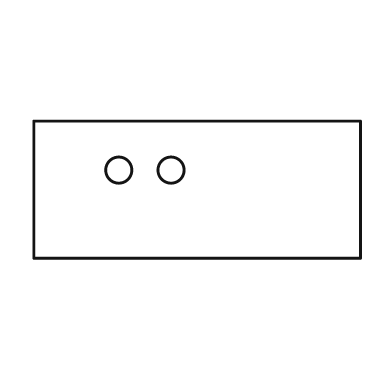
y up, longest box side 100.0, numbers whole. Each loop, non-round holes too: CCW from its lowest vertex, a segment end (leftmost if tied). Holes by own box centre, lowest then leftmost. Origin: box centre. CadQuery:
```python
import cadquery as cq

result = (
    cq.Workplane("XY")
    .moveTo(-50.0, -21.0)
    .lineTo(50.0, -21.0)
    .lineTo(50.0, 21.0)
    .lineTo(-50.0, 21.0)
    .close()
    .moveTo(-24.0, 6.0)
    .circle(4.0)
    .moveTo(-8.0, 6.0)
    .circle(4.0)
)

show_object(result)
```